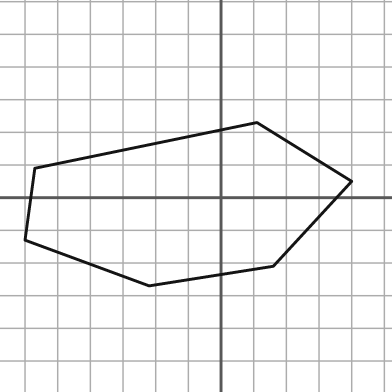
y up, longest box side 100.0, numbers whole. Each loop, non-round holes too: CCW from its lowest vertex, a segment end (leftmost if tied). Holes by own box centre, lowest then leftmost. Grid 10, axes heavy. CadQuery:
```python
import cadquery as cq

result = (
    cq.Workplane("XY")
    .moveTo(-22.0, -27.0)
    .lineTo(16.0, -21.0)
    .lineTo(40.0, 5.0)
    .lineTo(11.0, 23.0)
    .lineTo(-57.0, 9.0)
    .lineTo(-60.0, -13.0)
    .close()
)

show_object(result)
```